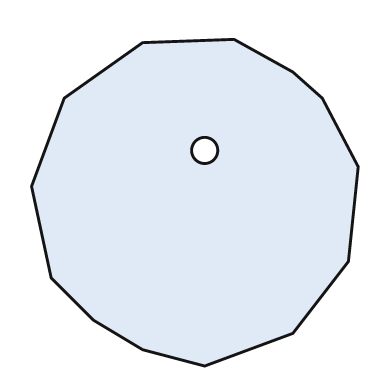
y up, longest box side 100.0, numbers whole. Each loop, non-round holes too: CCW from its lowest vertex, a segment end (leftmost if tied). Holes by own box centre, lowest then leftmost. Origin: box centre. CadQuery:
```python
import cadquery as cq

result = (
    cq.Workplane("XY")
    .moveTo(3.0, -50.0)
    .lineTo(30.0, -40.0)
    .lineTo(47.0, -18.0)
    .lineTo(50.0, 11.0)
    .lineTo(39.0, 32.0)
    .lineTo(30.0, 40.0)
    .lineTo(12.0, 50.0)
    .lineTo(-16.0, 49.0)
    .lineTo(-40.0, 32.0)
    .lineTo(-50.0, 5.0)
    .lineTo(-44.0, -23.0)
    .lineTo(-31.0, -36.0)
    .lineTo(-16.0, -45.0)
    .close()
    .moveTo(3.0, 16.0)
    .circle(4.0)
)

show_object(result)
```